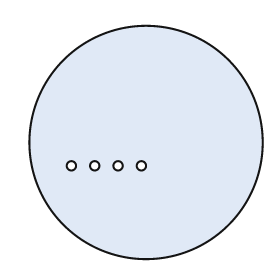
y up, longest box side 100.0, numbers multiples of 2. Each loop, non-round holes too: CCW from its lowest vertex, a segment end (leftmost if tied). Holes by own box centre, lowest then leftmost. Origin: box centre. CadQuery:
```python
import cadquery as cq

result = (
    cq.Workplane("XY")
    .moveTo(0.0, 0.0)
    .circle(50.0)
    .moveTo(-32.0, -10.0)
    .circle(2.0)
    .moveTo(-22.0, -10.0)
    .circle(2.0)
    .moveTo(-12.0, -10.0)
    .circle(2.0)
    .moveTo(-2.0, -10.0)
    .circle(2.0)
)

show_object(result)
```